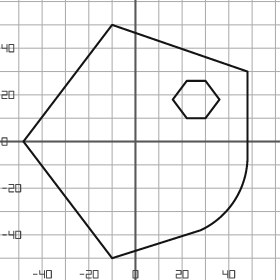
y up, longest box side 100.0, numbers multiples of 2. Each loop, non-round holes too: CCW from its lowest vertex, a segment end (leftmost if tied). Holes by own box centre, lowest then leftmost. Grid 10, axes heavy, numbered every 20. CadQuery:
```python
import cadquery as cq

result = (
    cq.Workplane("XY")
    .moveTo(-10.0, -50.0)
    .lineTo(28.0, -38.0)
    .threePointArc((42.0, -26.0), (48.0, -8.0))
    .lineTo(48.0, 30.0)
    .lineTo(-10.0, 50.0)
    .lineTo(-48.0, 0.0)
    .close()
    .moveTo(22.0, 10.0)
    .lineTo(30.0, 10.0)
    .lineTo(36.0, 18.0)
    .lineTo(30.0, 26.0)
    .lineTo(22.0, 26.0)
    .lineTo(16.0, 18.0)
    .close()
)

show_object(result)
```